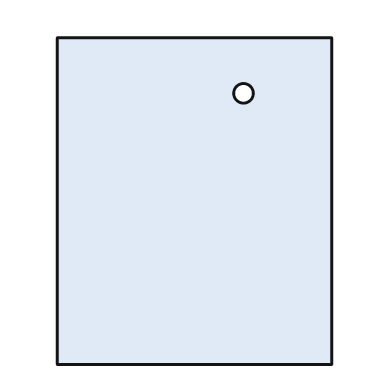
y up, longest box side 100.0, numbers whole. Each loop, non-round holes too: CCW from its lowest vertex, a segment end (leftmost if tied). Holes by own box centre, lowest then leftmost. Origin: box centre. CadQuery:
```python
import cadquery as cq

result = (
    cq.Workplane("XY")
    .moveTo(-42.0, -50.0)
    .lineTo(42.0, -50.0)
    .lineTo(42.0, 50.0)
    .lineTo(-42.0, 50.0)
    .close()
    .moveTo(15.0, 33.0)
    .circle(3.0)
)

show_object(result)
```